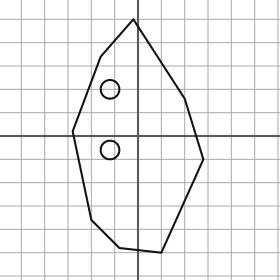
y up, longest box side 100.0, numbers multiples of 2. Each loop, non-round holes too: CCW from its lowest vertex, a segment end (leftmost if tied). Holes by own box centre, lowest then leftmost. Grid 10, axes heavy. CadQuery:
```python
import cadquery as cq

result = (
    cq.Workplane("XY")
    .moveTo(10.0, -50.0)
    .lineTo(28.0, -10.0)
    .lineTo(20.0, 16.0)
    .lineTo(-2.0, 50.0)
    .lineTo(-16.0, 34.0)
    .lineTo(-28.0, 2.0)
    .lineTo(-20.0, -36.0)
    .lineTo(-8.0, -48.0)
    .close()
    .moveTo(-12.0, -6.0)
    .circle(4.0)
    .moveTo(-12.0, 20.0)
    .circle(4.0)
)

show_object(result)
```